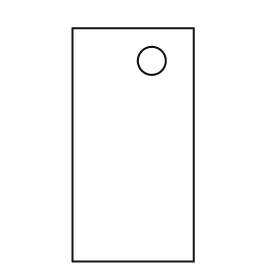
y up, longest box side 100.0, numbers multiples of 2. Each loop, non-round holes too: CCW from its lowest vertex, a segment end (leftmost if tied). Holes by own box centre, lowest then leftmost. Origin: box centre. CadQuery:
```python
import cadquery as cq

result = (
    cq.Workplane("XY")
    .moveTo(-26.0, -50.0)
    .lineTo(26.0, -50.0)
    .lineTo(26.0, 50.0)
    .lineTo(-26.0, 50.0)
    .close()
    .moveTo(8.0, 36.0)
    .circle(6.0)
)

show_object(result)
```